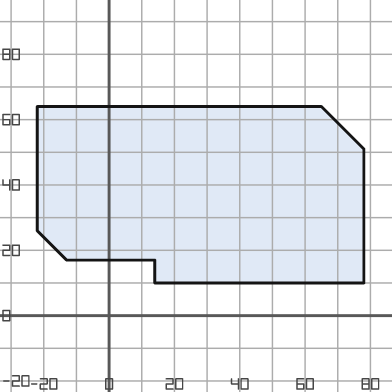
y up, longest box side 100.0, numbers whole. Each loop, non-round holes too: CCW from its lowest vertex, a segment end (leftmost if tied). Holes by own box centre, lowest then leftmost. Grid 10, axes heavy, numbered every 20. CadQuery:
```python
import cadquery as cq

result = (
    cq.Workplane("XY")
    .moveTo(14.0, 10.0)
    .lineTo(78.0, 10.0)
    .lineTo(78.0, 51.0)
    .lineTo(65.0, 64.0)
    .lineTo(-22.0, 64.0)
    .lineTo(-22.0, 26.0)
    .lineTo(-13.0, 17.0)
    .lineTo(14.0, 17.0)
    .close()
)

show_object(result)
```